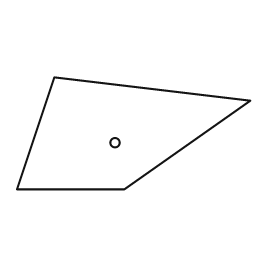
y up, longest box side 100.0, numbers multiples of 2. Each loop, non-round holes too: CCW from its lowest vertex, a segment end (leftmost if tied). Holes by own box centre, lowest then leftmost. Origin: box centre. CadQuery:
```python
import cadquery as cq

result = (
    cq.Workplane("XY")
    .moveTo(-50.0, -24.0)
    .lineTo(-4.0, -24.0)
    .lineTo(50.0, 14.0)
    .lineTo(-34.0, 24.0)
    .close()
    .moveTo(-8.0, -4.0)
    .circle(2.0)
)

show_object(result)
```